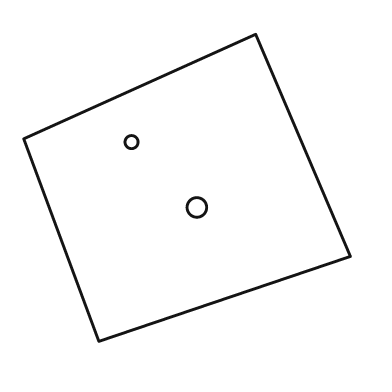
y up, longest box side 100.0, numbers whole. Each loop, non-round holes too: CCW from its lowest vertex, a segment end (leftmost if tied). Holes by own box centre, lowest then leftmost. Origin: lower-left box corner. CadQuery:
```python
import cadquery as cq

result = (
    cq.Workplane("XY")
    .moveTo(23.0, 0.0)
    .lineTo(100.0, 26.0)
    .lineTo(71.0, 94.0)
    .lineTo(0.0, 62.0)
    .close()
    .moveTo(53.0, 41.0)
    .circle(3.0)
    .moveTo(33.0, 61.0)
    .circle(2.0)
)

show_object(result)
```